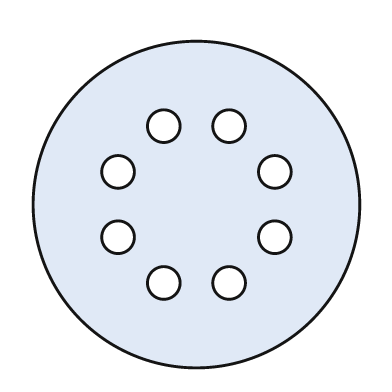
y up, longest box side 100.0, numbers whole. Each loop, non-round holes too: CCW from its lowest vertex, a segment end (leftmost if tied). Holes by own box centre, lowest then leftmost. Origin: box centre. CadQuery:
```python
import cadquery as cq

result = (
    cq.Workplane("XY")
    .moveTo(0.0, 0.0)
    .circle(50.0)
    .moveTo(-10.0, -24.0)
    .circle(5.0)
    .moveTo(10.0, -24.0)
    .circle(5.0)
    .moveTo(-24.0, -10.0)
    .circle(5.0)
    .moveTo(24.0, -10.0)
    .circle(5.0)
    .moveTo(-24.0, 10.0)
    .circle(5.0)
    .moveTo(24.0, 10.0)
    .circle(5.0)
    .moveTo(-10.0, 24.0)
    .circle(5.0)
    .moveTo(10.0, 24.0)
    .circle(5.0)
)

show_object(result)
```